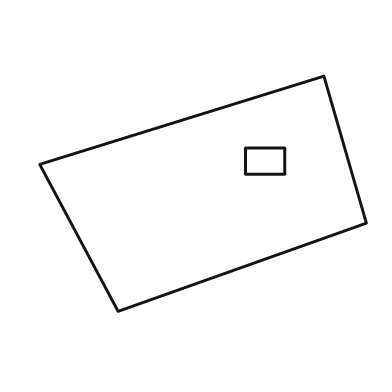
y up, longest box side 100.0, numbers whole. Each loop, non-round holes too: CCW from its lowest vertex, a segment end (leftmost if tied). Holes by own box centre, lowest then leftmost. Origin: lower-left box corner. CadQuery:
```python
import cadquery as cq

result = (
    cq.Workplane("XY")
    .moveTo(24.0, 0.0)
    .lineTo(100.0, 27.0)
    .lineTo(87.0, 72.0)
    .lineTo(0.0, 45.0)
    .close()
    .moveTo(63.0, 42.0)
    .lineTo(75.0, 42.0)
    .lineTo(75.0, 50.0)
    .lineTo(63.0, 50.0)
    .close()
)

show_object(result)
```